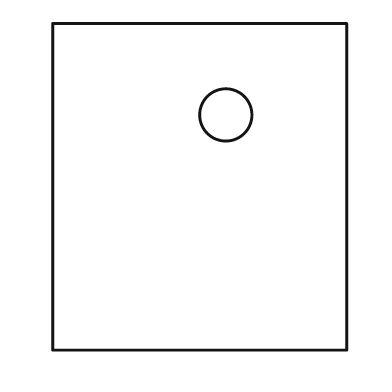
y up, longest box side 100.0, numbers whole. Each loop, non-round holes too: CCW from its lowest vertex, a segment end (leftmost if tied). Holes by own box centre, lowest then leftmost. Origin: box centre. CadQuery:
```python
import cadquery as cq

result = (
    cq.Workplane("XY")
    .moveTo(-45.0, -50.0)
    .lineTo(45.0, -50.0)
    .lineTo(45.0, 50.0)
    .lineTo(-45.0, 50.0)
    .close()
    .moveTo(8.0, 22.0)
    .circle(8.0)
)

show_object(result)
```